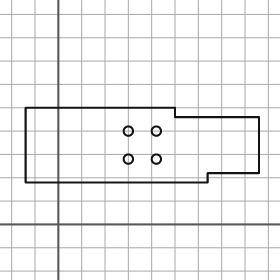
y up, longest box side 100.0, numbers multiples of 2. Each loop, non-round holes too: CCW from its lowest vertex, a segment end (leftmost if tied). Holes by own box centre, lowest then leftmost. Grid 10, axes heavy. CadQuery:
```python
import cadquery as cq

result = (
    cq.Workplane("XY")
    .moveTo(-14.0, 18.0)
    .lineTo(64.0, 18.0)
    .lineTo(64.0, 22.0)
    .lineTo(86.0, 22.0)
    .lineTo(86.0, 46.0)
    .lineTo(50.0, 46.0)
    .lineTo(50.0, 50.0)
    .lineTo(-14.0, 50.0)
    .close()
    .moveTo(30.0, 28.0)
    .circle(2.0)
    .moveTo(42.0, 28.0)
    .circle(2.0)
    .moveTo(30.0, 40.0)
    .circle(2.0)
    .moveTo(42.0, 40.0)
    .circle(2.0)
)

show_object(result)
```